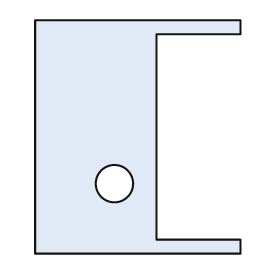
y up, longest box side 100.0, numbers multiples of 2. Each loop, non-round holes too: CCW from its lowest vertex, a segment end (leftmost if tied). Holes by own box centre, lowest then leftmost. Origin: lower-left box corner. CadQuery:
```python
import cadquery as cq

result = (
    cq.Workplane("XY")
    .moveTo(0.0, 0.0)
    .lineTo(88.0, 0.0)
    .lineTo(88.0, 6.0)
    .lineTo(52.0, 6.0)
    .lineTo(52.0, 94.0)
    .lineTo(88.0, 94.0)
    .lineTo(88.0, 100.0)
    .lineTo(0.0, 100.0)
    .close()
    .moveTo(34.0, 30.0)
    .circle(8.0)
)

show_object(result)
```